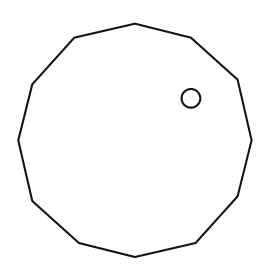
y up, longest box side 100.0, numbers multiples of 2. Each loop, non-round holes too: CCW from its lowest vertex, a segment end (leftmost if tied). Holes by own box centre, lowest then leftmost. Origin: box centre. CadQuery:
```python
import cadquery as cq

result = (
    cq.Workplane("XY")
    .moveTo(0.0, -50.0)
    .lineTo(26.0, -44.0)
    .lineTo(44.0, -24.0)
    .lineTo(50.0, 0.0)
    .lineTo(44.0, 26.0)
    .lineTo(24.0, 44.0)
    .lineTo(0.0, 50.0)
    .lineTo(-26.0, 44.0)
    .lineTo(-44.0, 24.0)
    .lineTo(-50.0, 0.0)
    .lineTo(-44.0, -26.0)
    .lineTo(-24.0, -44.0)
    .close()
    .moveTo(24.0, 18.0)
    .circle(4.0)
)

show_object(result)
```